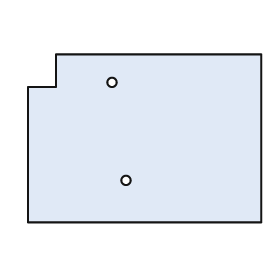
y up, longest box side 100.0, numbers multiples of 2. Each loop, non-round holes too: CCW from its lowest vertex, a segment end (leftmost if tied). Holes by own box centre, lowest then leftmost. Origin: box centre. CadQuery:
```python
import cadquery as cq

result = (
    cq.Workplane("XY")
    .moveTo(-50.0, -36.0)
    .lineTo(50.0, -36.0)
    .lineTo(50.0, 36.0)
    .lineTo(-38.0, 36.0)
    .lineTo(-38.0, 22.0)
    .lineTo(-50.0, 22.0)
    .close()
    .moveTo(-8.0, -18.0)
    .circle(2.0)
    .moveTo(-14.0, 24.0)
    .circle(2.0)
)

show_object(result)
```